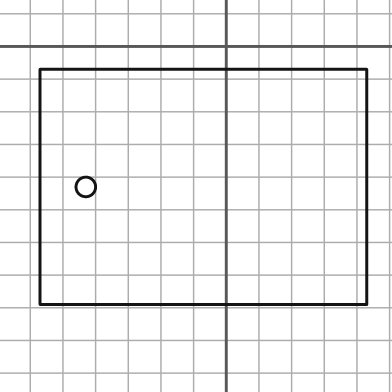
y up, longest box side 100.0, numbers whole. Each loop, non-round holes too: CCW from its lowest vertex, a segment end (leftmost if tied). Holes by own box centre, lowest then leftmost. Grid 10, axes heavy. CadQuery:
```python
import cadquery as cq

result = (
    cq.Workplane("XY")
    .moveTo(-57.0, -79.0)
    .lineTo(43.0, -79.0)
    .lineTo(43.0, -7.0)
    .lineTo(-57.0, -7.0)
    .close()
    .moveTo(-43.0, -43.0)
    .circle(3.0)
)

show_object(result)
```